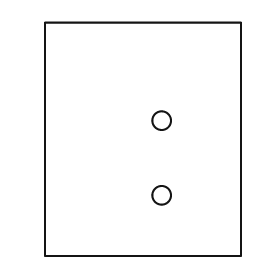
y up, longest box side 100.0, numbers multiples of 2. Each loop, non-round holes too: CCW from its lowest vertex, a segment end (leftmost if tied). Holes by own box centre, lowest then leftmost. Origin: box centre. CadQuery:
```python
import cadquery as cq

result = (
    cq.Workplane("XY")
    .moveTo(-42.0, -50.0)
    .lineTo(42.0, -50.0)
    .lineTo(42.0, 50.0)
    .lineTo(-42.0, 50.0)
    .close()
    .moveTo(8.0, -24.0)
    .circle(4.0)
    .moveTo(8.0, 8.0)
    .circle(4.0)
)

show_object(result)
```